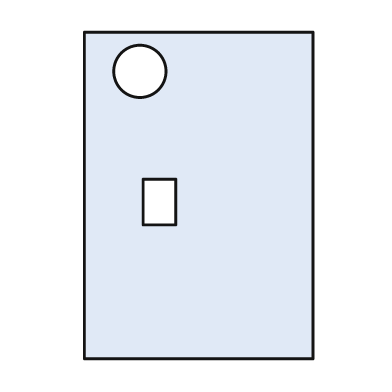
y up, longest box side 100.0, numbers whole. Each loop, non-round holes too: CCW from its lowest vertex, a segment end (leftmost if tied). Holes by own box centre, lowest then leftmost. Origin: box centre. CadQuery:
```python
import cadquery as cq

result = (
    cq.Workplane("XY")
    .moveTo(-35.0, -50.0)
    .lineTo(35.0, -50.0)
    .lineTo(35.0, 50.0)
    .lineTo(-35.0, 50.0)
    .close()
    .moveTo(-17.0, -9.0)
    .lineTo(-7.0, -9.0)
    .lineTo(-7.0, 5.0)
    .lineTo(-17.0, 5.0)
    .close()
    .moveTo(-18.0, 38.0)
    .circle(8.0)
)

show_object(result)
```